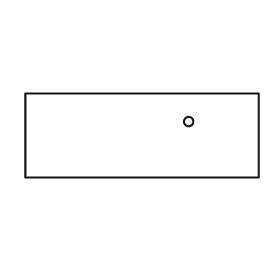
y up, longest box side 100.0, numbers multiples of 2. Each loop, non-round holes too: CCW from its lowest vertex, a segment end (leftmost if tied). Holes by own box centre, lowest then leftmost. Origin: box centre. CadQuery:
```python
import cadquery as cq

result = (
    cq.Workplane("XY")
    .moveTo(-50.0, -18.0)
    .lineTo(50.0, -18.0)
    .lineTo(50.0, 18.0)
    .lineTo(-50.0, 18.0)
    .close()
    .moveTo(20.0, 6.0)
    .circle(2.0)
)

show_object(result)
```